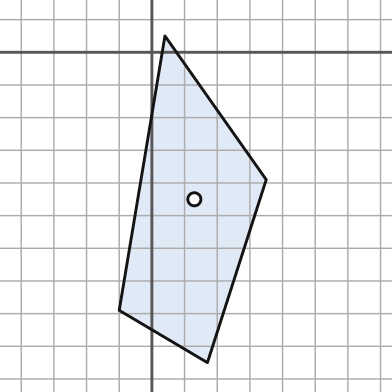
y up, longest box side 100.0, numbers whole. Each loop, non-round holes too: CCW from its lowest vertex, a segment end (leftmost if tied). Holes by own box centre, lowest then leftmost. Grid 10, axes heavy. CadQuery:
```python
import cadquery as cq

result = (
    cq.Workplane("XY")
    .moveTo(17.0, -95.0)
    .lineTo(35.0, -39.0)
    .lineTo(4.0, 5.0)
    .lineTo(-10.0, -79.0)
    .close()
    .moveTo(13.0, -45.0)
    .circle(2.0)
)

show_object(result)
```